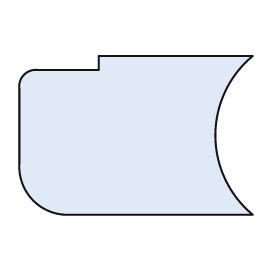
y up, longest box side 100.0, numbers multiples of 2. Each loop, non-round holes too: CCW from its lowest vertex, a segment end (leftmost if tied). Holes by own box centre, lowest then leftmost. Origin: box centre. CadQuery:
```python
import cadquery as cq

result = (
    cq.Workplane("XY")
    .moveTo(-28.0, -34.0)
    .lineTo(50.0, -34.0)
    .threePointArc((34.0, 0.0), (50.0, 34.0))
    .lineTo(-16.0, 34.0)
    .lineTo(-16.0, 28.0)
    .lineTo(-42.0, 28.0)
    .threePointArc((-48.0, 26.0), (-50.0, 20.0))
    .lineTo(-50.0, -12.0)
    .threePointArc((-44.0, -28.0), (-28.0, -34.0))
    .close()
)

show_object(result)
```